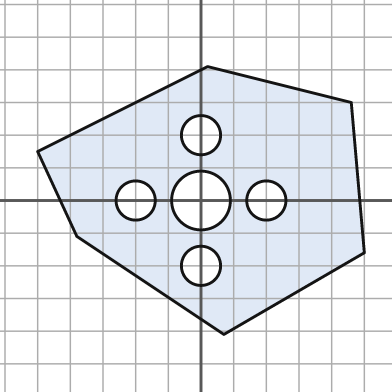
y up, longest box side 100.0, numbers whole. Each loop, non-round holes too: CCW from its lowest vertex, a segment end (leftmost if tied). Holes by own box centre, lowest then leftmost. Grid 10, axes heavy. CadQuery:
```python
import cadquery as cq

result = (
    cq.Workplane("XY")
    .moveTo(7.0, -41.0)
    .lineTo(50.0, -16.0)
    .lineTo(46.0, 30.0)
    .lineTo(2.0, 41.0)
    .lineTo(-50.0, 15.0)
    .lineTo(-38.0, -11.0)
    .close()
    .moveTo(0.0, -20.0)
    .circle(6.0)
    .moveTo(-20.0, 0.0)
    .circle(6.0)
    .moveTo(0.0, 0.0)
    .circle(9.0)
    .moveTo(20.0, 0.0)
    .circle(6.0)
    .moveTo(0.0, 20.0)
    .circle(6.0)
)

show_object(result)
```